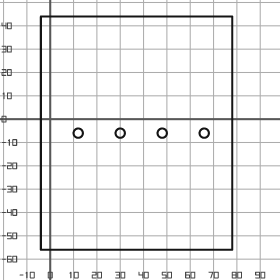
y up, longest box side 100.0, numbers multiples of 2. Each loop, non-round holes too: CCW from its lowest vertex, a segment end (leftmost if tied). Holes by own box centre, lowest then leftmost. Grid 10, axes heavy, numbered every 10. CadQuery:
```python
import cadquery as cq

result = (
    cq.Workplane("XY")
    .moveTo(-4.0, -56.0)
    .lineTo(78.0, -56.0)
    .lineTo(78.0, 44.0)
    .lineTo(-4.0, 44.0)
    .close()
    .moveTo(12.0, -6.0)
    .circle(2.0)
    .moveTo(30.0, -6.0)
    .circle(2.0)
    .moveTo(48.0, -6.0)
    .circle(2.0)
    .moveTo(66.0, -6.0)
    .circle(2.0)
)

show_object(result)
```